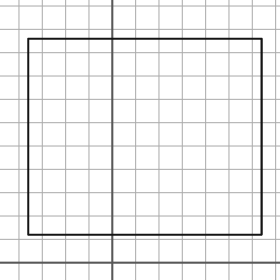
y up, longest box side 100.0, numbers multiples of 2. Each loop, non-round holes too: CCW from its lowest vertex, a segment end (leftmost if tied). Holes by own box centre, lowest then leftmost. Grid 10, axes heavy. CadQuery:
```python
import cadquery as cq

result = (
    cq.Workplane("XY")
    .moveTo(-36.0, 12.0)
    .lineTo(64.0, 12.0)
    .lineTo(64.0, 96.0)
    .lineTo(-36.0, 96.0)
    .close()
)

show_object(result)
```